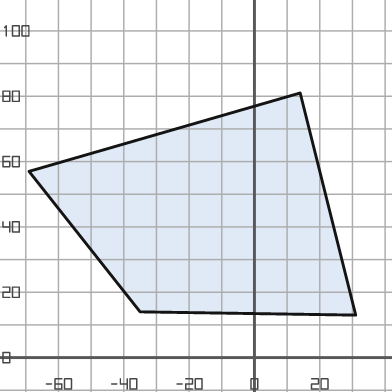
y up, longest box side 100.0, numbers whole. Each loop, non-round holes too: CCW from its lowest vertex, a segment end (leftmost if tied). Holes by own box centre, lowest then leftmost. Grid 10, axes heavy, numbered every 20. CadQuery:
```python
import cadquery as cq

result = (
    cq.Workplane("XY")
    .moveTo(31.0, 13.0)
    .lineTo(14.0, 81.0)
    .lineTo(-69.0, 57.0)
    .lineTo(-35.0, 14.0)
    .close()
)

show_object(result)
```